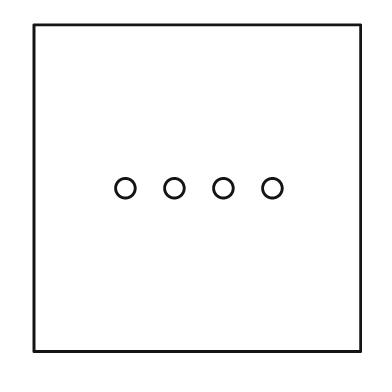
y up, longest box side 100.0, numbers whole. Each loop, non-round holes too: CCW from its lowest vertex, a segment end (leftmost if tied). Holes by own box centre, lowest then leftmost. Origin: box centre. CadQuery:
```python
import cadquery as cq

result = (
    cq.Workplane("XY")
    .moveTo(-50.0, -50.0)
    .lineTo(50.0, -50.0)
    .lineTo(50.0, 50.0)
    .lineTo(-50.0, 50.0)
    .close()
    .moveTo(-22.0, 0.0)
    .circle(3.0)
    .moveTo(-7.0, 0.0)
    .circle(3.0)
    .moveTo(8.0, 0.0)
    .circle(3.0)
    .moveTo(23.0, 0.0)
    .circle(3.0)
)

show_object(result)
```